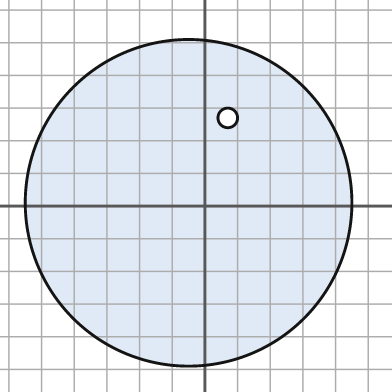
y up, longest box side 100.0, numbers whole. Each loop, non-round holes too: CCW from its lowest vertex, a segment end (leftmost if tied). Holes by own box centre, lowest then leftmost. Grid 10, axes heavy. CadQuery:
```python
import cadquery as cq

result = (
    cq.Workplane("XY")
    .moveTo(-5.0, 1.0)
    .circle(50.0)
    .moveTo(7.0, 27.0)
    .circle(3.0)
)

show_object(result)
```